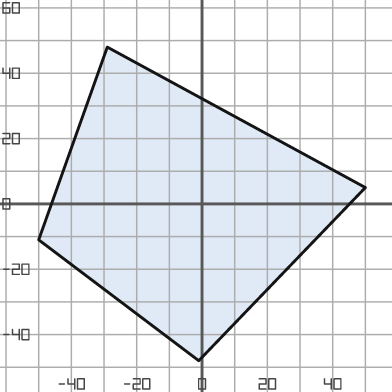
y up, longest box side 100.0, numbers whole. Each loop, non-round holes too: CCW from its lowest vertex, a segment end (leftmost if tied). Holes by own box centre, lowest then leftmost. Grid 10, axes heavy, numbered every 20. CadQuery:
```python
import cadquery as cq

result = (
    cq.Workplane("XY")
    .moveTo(-1.0, -48.0)
    .lineTo(50.0, 5.0)
    .lineTo(-29.0, 48.0)
    .lineTo(-50.0, -11.0)
    .close()
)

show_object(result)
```